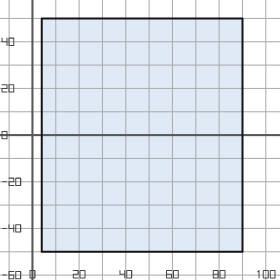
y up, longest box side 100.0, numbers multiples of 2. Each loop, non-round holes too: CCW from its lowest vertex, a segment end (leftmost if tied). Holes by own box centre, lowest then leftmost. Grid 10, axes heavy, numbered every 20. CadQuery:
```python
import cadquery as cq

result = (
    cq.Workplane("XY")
    .moveTo(4.0, -50.0)
    .lineTo(90.0, -50.0)
    .lineTo(90.0, 50.0)
    .lineTo(4.0, 50.0)
    .close()
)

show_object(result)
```